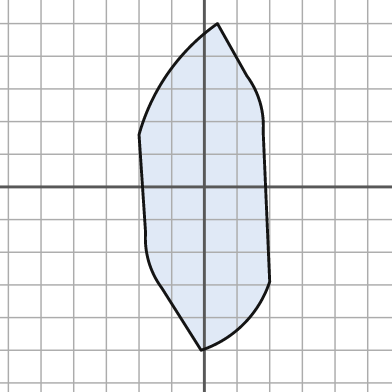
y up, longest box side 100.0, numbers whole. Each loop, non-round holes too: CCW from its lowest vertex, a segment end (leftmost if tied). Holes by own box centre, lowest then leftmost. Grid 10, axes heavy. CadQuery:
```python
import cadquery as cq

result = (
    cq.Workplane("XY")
    .moveTo(-1.0, -50.0)
    .threePointArc((12.0, -42.0), (20.0, -29.0))
    .lineTo(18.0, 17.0)
    .threePointArc((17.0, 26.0), (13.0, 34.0))
    .lineTo(4.0, 50.0)
    .threePointArc((-11.0, 35.0), (-20.0, 16.0))
    .lineTo(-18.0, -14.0)
    .threePointArc((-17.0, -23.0), (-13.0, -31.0))
    .close()
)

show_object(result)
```